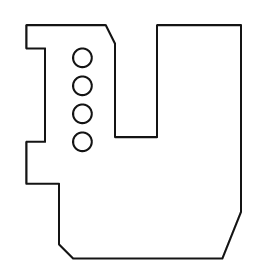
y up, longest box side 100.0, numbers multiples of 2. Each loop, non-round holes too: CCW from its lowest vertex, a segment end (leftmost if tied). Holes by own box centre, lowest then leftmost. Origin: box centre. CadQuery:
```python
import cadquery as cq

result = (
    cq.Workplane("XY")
    .moveTo(-26.0, -50.0)
    .lineTo(38.0, -50.0)
    .lineTo(46.0, -30.0)
    .lineTo(46.0, 50.0)
    .lineTo(10.0, 50.0)
    .lineTo(10.0, 2.0)
    .lineTo(-8.0, 2.0)
    .lineTo(-8.0, 42.0)
    .lineTo(-12.0, 50.0)
    .lineTo(-46.0, 50.0)
    .lineTo(-46.0, 40.0)
    .lineTo(-38.0, 40.0)
    .lineTo(-38.0, 0.0)
    .lineTo(-46.0, 0.0)
    .lineTo(-46.0, -18.0)
    .lineTo(-32.0, -18.0)
    .lineTo(-32.0, -44.0)
    .close()
    .moveTo(-22.0, 0.0)
    .circle(4.0)
    .moveTo(-22.0, 12.0)
    .circle(4.0)
    .moveTo(-22.0, 24.0)
    .circle(4.0)
    .moveTo(-22.0, 36.0)
    .circle(4.0)
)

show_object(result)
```